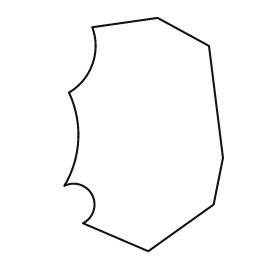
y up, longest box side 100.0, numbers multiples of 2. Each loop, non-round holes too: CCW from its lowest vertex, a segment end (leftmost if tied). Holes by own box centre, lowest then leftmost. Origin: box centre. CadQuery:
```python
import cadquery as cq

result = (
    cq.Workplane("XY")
    .moveTo(2.0, -50.0)
    .lineTo(30.0, -30.0)
    .lineTo(34.0, -10.0)
    .lineTo(28.0, 38.0)
    .lineTo(6.0, 50.0)
    .lineTo(-22.0, 46.0)
    .threePointArc((-22.0, 30.0), (-32.0, 18.0))
    .threePointArc((-28.0, -2.0), (-34.0, -22.0))
    .threePointArc((-22.0, -26.0), (-26.0, -38.0))
    .close()
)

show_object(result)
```